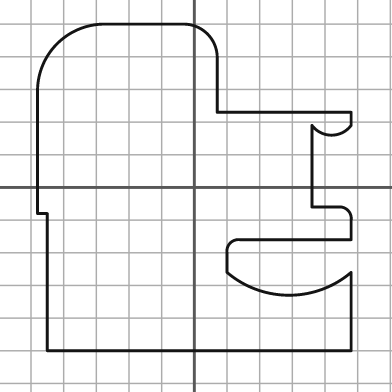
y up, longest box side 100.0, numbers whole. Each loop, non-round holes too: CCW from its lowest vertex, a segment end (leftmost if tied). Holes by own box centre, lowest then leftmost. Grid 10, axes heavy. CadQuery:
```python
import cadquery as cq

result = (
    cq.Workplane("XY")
    .moveTo(-45.0, -50.0)
    .lineTo(48.0, -50.0)
    .lineTo(48.0, -26.0)
    .threePointArc((29.0, -33.0), (10.0, -26.0))
    .lineTo(10.0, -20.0)
    .threePointArc((11.0, -17.0), (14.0, -16.0))
    .lineTo(48.0, -16.0)
    .lineTo(48.0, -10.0)
    .threePointArc((47.0, -7.0), (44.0, -6.0))
    .lineTo(36.0, -6.0)
    .lineTo(36.0, 19.0)
    .threePointArc((42.0, 16.0), (48.0, 19.0))
    .lineTo(48.0, 23.0)
    .lineTo(7.0, 23.0)
    .lineTo(7.0, 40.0)
    .threePointArc((4.0, 47.0), (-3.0, 50.0))
    .lineTo(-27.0, 50.0)
    .threePointArc((-42.0, 44.0), (-48.0, 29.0))
    .lineTo(-48.0, -8.0)
    .lineTo(-45.0, -8.0)
    .close()
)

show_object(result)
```